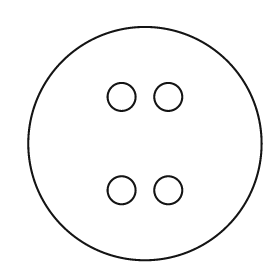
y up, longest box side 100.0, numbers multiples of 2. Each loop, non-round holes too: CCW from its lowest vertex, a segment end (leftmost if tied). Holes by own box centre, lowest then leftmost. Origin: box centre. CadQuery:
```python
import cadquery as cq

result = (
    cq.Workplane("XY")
    .moveTo(0.0, 0.0)
    .circle(50.0)
    .moveTo(-10.0, -20.0)
    .circle(6.0)
    .moveTo(10.0, -20.0)
    .circle(6.0)
    .moveTo(-10.0, 20.0)
    .circle(6.0)
    .moveTo(10.0, 20.0)
    .circle(6.0)
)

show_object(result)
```